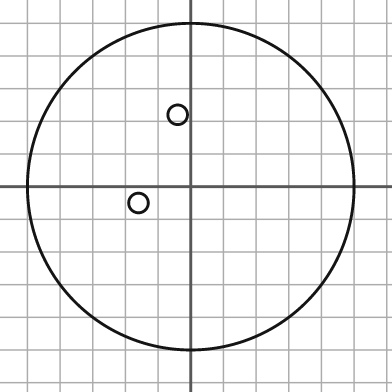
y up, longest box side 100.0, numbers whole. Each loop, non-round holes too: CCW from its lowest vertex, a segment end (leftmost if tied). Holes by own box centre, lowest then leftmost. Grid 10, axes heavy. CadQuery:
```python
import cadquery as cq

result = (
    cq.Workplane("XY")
    .moveTo(0.0, 0.0)
    .circle(50.0)
    .moveTo(-16.0, -5.0)
    .circle(3.0)
    .moveTo(-4.0, 22.0)
    .circle(3.0)
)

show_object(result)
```